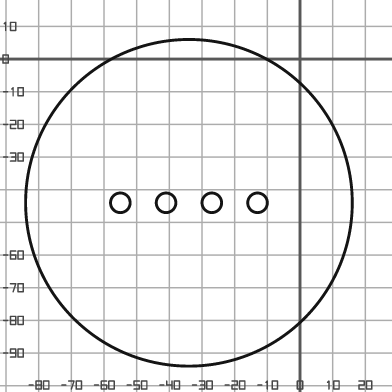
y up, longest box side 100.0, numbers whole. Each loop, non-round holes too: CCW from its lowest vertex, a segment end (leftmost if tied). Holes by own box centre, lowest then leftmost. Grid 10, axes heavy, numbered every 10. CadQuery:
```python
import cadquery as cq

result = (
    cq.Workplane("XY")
    .moveTo(-34.0, -44.0)
    .circle(50.0)
    .moveTo(-55.0, -44.0)
    .circle(3.0)
    .moveTo(-41.0, -44.0)
    .circle(3.0)
    .moveTo(-27.0, -44.0)
    .circle(3.0)
    .moveTo(-13.0, -44.0)
    .circle(3.0)
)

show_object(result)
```